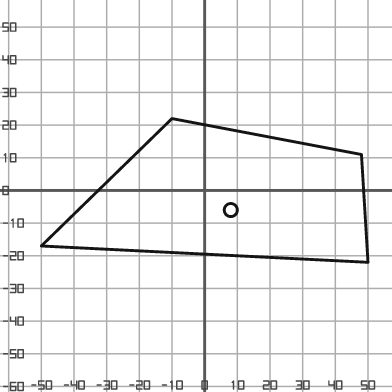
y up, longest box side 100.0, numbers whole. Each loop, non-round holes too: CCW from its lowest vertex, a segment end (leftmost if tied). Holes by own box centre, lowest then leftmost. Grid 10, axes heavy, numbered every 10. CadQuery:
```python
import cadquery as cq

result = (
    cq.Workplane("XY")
    .moveTo(50.0, -22.0)
    .lineTo(48.0, 11.0)
    .lineTo(-10.0, 22.0)
    .lineTo(-50.0, -17.0)
    .close()
    .moveTo(8.0, -6.0)
    .circle(2.0)
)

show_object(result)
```